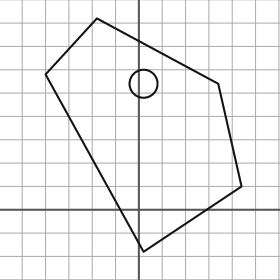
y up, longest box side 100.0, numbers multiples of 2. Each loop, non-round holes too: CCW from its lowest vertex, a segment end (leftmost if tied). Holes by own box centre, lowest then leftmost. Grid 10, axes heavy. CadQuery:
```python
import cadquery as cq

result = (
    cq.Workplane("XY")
    .moveTo(2.0, -18.0)
    .lineTo(44.0, 10.0)
    .lineTo(34.0, 54.0)
    .lineTo(-18.0, 82.0)
    .lineTo(-40.0, 58.0)
    .close()
    .moveTo(2.0, 54.0)
    .circle(6.0)
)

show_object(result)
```